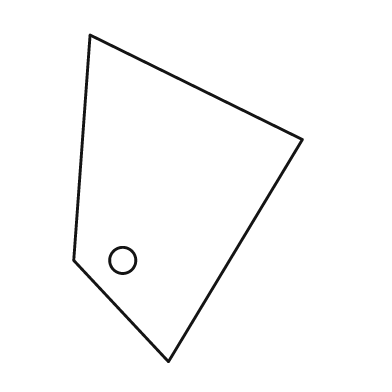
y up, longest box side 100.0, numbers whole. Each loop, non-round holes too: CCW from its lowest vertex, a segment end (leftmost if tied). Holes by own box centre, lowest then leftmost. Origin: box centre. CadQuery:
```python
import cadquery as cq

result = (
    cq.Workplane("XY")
    .moveTo(-6.0, -50.0)
    .lineTo(35.0, 18.0)
    .lineTo(-30.0, 50.0)
    .lineTo(-35.0, -19.0)
    .close()
    .moveTo(-20.0, -19.0)
    .circle(4.0)
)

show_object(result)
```